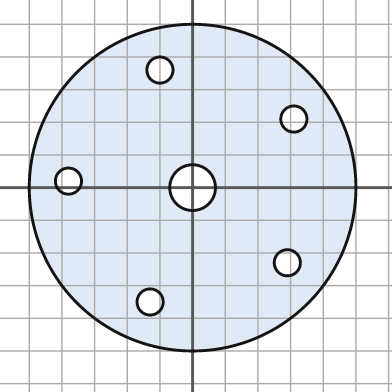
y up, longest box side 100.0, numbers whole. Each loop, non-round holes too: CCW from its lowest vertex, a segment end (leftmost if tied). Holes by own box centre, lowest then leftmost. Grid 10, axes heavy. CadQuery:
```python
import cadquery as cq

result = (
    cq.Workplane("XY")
    .moveTo(0.0, 0.0)
    .circle(50.0)
    .moveTo(-13.0, -35.0)
    .circle(4.0)
    .moveTo(29.0, -23.0)
    .circle(4.0)
    .moveTo(0.0, 0.0)
    .circle(7.0)
    .moveTo(-38.0, 2.0)
    .circle(4.0)
    .moveTo(31.0, 21.0)
    .circle(4.0)
    .moveTo(-10.0, 36.0)
    .circle(4.0)
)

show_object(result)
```